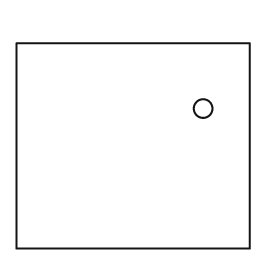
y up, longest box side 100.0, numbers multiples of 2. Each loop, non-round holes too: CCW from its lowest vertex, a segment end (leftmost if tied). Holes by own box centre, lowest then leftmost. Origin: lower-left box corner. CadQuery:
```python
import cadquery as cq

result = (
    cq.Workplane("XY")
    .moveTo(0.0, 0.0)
    .lineTo(100.0, 0.0)
    .lineTo(100.0, 88.0)
    .lineTo(0.0, 88.0)
    .close()
    .moveTo(80.0, 60.0)
    .circle(4.0)
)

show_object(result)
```